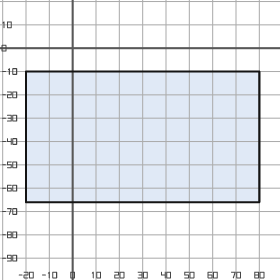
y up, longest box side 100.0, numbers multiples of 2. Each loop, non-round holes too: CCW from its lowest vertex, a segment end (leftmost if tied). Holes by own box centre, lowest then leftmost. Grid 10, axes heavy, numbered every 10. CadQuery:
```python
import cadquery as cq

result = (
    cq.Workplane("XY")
    .moveTo(-20.0, -66.0)
    .lineTo(80.0, -66.0)
    .lineTo(80.0, -10.0)
    .lineTo(-20.0, -10.0)
    .close()
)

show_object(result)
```